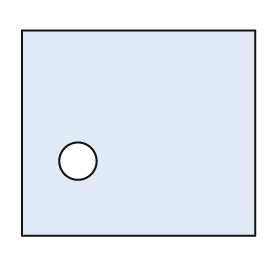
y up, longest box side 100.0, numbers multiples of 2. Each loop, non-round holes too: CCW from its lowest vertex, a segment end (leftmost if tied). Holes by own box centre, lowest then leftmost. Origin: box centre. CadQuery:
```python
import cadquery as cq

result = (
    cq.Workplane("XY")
    .moveTo(-50.0, -44.0)
    .lineTo(50.0, -44.0)
    .lineTo(50.0, 44.0)
    .lineTo(-50.0, 44.0)
    .close()
    .moveTo(-26.0, -12.0)
    .circle(8.0)
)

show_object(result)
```